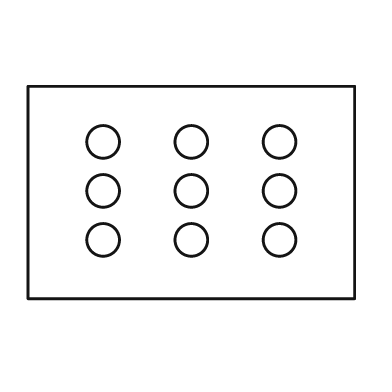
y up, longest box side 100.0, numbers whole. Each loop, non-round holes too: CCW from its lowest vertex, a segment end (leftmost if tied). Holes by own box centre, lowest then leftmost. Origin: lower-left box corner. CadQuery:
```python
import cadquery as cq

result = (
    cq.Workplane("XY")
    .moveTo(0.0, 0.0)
    .lineTo(100.0, 0.0)
    .lineTo(100.0, 65.0)
    .lineTo(0.0, 65.0)
    .close()
    .moveTo(23.0, 18.0)
    .circle(5.0)
    .moveTo(50.0, 18.0)
    .circle(5.0)
    .moveTo(77.0, 18.0)
    .circle(5.0)
    .moveTo(23.0, 33.0)
    .circle(5.0)
    .moveTo(50.0, 33.0)
    .circle(5.0)
    .moveTo(77.0, 33.0)
    .circle(5.0)
    .moveTo(23.0, 48.0)
    .circle(5.0)
    .moveTo(50.0, 48.0)
    .circle(5.0)
    .moveTo(77.0, 48.0)
    .circle(5.0)
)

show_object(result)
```